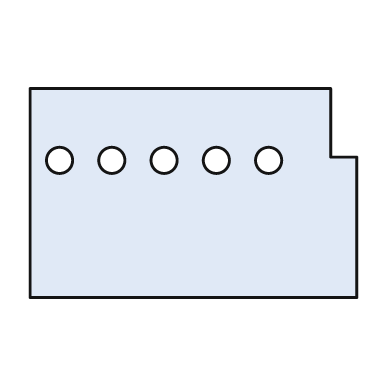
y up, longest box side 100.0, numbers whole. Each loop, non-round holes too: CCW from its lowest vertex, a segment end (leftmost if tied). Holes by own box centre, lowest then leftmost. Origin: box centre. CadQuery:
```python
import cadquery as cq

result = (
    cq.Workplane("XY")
    .moveTo(-50.0, -32.0)
    .lineTo(50.0, -32.0)
    .lineTo(50.0, 11.0)
    .lineTo(42.0, 11.0)
    .lineTo(42.0, 32.0)
    .lineTo(-50.0, 32.0)
    .close()
    .moveTo(-41.0, 10.0)
    .circle(4.0)
    .moveTo(-25.0, 10.0)
    .circle(4.0)
    .moveTo(-9.0, 10.0)
    .circle(4.0)
    .moveTo(7.0, 10.0)
    .circle(4.0)
    .moveTo(23.0, 10.0)
    .circle(4.0)
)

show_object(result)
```